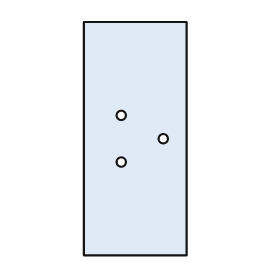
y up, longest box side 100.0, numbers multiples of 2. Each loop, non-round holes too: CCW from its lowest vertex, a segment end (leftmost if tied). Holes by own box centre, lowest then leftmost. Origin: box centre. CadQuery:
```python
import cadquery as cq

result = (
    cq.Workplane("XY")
    .moveTo(-22.0, -50.0)
    .lineTo(22.0, -50.0)
    .lineTo(22.0, 50.0)
    .lineTo(-22.0, 50.0)
    .close()
    .moveTo(-6.0, -10.0)
    .circle(2.0)
    .moveTo(12.0, 0.0)
    .circle(2.0)
    .moveTo(-6.0, 10.0)
    .circle(2.0)
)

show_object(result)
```